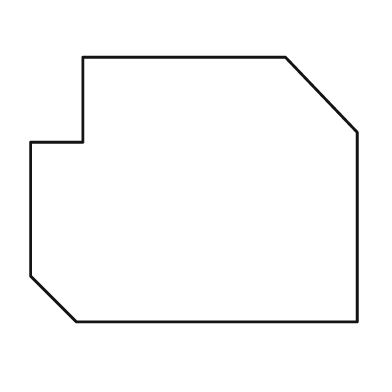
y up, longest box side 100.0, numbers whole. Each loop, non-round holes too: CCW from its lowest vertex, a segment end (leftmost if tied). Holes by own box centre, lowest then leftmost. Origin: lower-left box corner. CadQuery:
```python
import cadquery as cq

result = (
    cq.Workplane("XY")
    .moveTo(14.0, 0.0)
    .lineTo(100.0, 0.0)
    .lineTo(100.0, 58.0)
    .lineTo(78.0, 81.0)
    .lineTo(16.0, 81.0)
    .lineTo(16.0, 55.0)
    .lineTo(0.0, 55.0)
    .lineTo(0.0, 14.0)
    .close()
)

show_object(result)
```